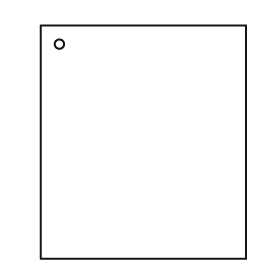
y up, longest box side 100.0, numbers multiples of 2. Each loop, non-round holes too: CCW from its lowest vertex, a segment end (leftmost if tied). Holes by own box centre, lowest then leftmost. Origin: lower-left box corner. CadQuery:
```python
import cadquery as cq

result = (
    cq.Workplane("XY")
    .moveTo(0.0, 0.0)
    .lineTo(88.0, 0.0)
    .lineTo(88.0, 100.0)
    .lineTo(0.0, 100.0)
    .close()
    .moveTo(8.0, 92.0)
    .circle(2.0)
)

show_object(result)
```